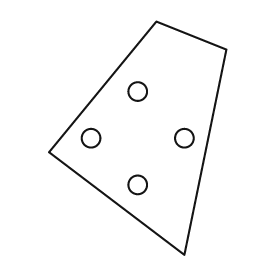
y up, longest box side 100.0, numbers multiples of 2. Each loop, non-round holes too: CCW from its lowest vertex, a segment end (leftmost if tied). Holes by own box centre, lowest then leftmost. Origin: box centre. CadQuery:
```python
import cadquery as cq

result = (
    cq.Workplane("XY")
    .moveTo(20.0, -50.0)
    .lineTo(38.0, 38.0)
    .lineTo(8.0, 50.0)
    .lineTo(-38.0, -6.0)
    .close()
    .moveTo(0.0, -20.0)
    .circle(4.0)
    .moveTo(-20.0, 0.0)
    .circle(4.0)
    .moveTo(20.0, 0.0)
    .circle(4.0)
    .moveTo(0.0, 20.0)
    .circle(4.0)
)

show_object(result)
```